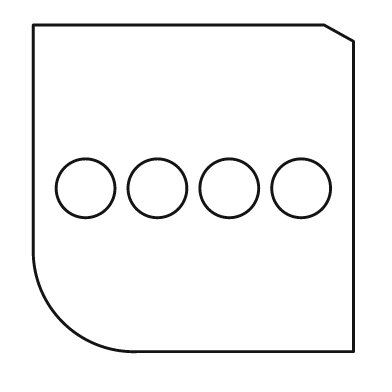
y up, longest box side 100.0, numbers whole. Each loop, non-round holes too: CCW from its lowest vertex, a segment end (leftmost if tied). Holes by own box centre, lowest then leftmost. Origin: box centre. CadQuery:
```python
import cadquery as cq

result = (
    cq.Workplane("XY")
    .moveTo(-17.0, -50.0)
    .lineTo(49.0, -50.0)
    .lineTo(49.0, 45.0)
    .lineTo(40.0, 50.0)
    .lineTo(-49.0, 50.0)
    .lineTo(-49.0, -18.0)
    .threePointArc((-40.0, -41.0), (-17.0, -50.0))
    .close()
    .moveTo(-33.0, 0.0)
    .circle(9.0)
    .moveTo(-11.0, 0.0)
    .circle(9.0)
    .moveTo(11.0, 0.0)
    .circle(9.0)
    .moveTo(33.0, 0.0)
    .circle(9.0)
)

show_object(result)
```